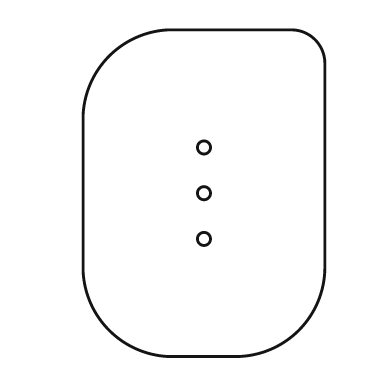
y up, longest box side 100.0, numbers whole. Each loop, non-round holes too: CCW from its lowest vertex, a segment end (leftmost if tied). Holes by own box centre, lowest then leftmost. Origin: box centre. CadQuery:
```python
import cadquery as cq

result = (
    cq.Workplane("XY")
    .moveTo(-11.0, -50.0)
    .lineTo(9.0, -50.0)
    .threePointArc((29.0, -42.0), (37.0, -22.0))
    .lineTo(37.0, 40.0)
    .threePointArc((34.0, 47.0), (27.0, 50.0))
    .lineTo(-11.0, 50.0)
    .threePointArc((-29.0, 42.0), (-37.0, 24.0))
    .lineTo(-37.0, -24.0)
    .threePointArc((-29.0, -42.0), (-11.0, -50.0))
    .close()
    .moveTo(0.0, -14.0)
    .circle(2.0)
    .moveTo(0.0, 0.0)
    .circle(2.0)
    .moveTo(0.0, 14.0)
    .circle(2.0)
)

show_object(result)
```